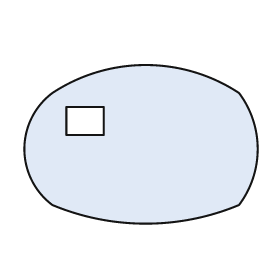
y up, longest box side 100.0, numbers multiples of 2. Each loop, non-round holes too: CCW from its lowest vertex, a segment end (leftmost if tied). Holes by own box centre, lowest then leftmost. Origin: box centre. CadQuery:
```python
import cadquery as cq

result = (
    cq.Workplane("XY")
    .moveTo(-38.0, -26.0)
    .threePointArc((2.0, -34.0), (42.0, -26.0))
    .threePointArc((50.0, -2.0), (42.0, 22.0))
    .threePointArc((2.0, 34.0), (-38.0, 22.0))
    .threePointArc((-50.0, -2.0), (-38.0, -26.0))
    .close()
    .moveTo(-32.0, 4.0)
    .lineTo(-16.0, 4.0)
    .lineTo(-16.0, 16.0)
    .lineTo(-32.0, 16.0)
    .close()
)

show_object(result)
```